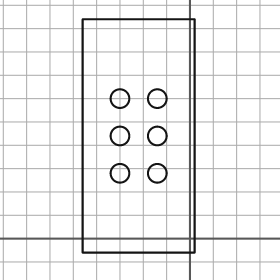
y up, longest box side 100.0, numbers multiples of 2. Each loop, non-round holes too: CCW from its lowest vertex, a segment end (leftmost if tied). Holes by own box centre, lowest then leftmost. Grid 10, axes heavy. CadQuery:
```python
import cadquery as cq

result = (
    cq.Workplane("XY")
    .moveTo(-46.0, -6.0)
    .lineTo(2.0, -6.0)
    .lineTo(2.0, 94.0)
    .lineTo(-46.0, 94.0)
    .close()
    .moveTo(-30.0, 28.0)
    .circle(4.0)
    .moveTo(-14.0, 28.0)
    .circle(4.0)
    .moveTo(-30.0, 44.0)
    .circle(4.0)
    .moveTo(-14.0, 44.0)
    .circle(4.0)
    .moveTo(-30.0, 60.0)
    .circle(4.0)
    .moveTo(-14.0, 60.0)
    .circle(4.0)
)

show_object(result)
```